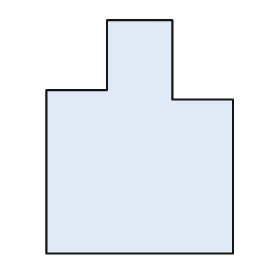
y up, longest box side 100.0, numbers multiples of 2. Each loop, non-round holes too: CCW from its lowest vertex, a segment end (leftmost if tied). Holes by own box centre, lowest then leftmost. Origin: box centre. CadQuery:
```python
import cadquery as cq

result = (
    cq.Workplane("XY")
    .moveTo(-40.0, -50.0)
    .lineTo(40.0, -50.0)
    .lineTo(40.0, 16.0)
    .lineTo(14.0, 16.0)
    .lineTo(14.0, 50.0)
    .lineTo(-14.0, 50.0)
    .lineTo(-14.0, 20.0)
    .lineTo(-40.0, 20.0)
    .close()
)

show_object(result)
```